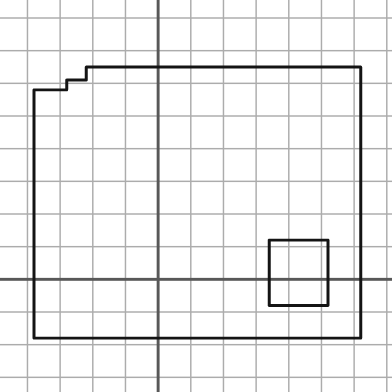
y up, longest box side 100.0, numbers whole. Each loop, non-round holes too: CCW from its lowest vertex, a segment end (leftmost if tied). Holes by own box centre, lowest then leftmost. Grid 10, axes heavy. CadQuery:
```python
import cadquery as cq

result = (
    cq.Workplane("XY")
    .moveTo(-38.0, -18.0)
    .lineTo(62.0, -18.0)
    .lineTo(62.0, 65.0)
    .lineTo(-22.0, 65.0)
    .lineTo(-22.0, 61.0)
    .lineTo(-28.0, 61.0)
    .lineTo(-28.0, 58.0)
    .lineTo(-38.0, 58.0)
    .close()
    .moveTo(34.0, -8.0)
    .lineTo(52.0, -8.0)
    .lineTo(52.0, 12.0)
    .lineTo(34.0, 12.0)
    .close()
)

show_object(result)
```